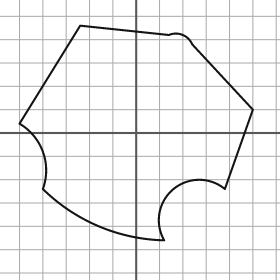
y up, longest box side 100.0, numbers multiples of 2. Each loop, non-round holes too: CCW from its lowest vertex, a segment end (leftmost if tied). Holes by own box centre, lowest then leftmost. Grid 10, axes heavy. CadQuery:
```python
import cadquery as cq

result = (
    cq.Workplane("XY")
    .moveTo(12.0, -46.0)
    .threePointArc((16.0, -24.0), (38.0, -24.0))
    .lineTo(50.0, 10.0)
    .lineTo(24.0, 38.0)
    .threePointArc((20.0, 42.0), (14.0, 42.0))
    .lineTo(-24.0, 46.0)
    .lineTo(-50.0, 4.0)
    .threePointArc((-40.0, -8.0), (-40.0, -24.0))
    .threePointArc((-16.0, -40.0), (12.0, -46.0))
    .close()
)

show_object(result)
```